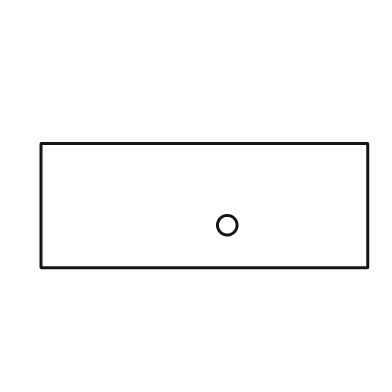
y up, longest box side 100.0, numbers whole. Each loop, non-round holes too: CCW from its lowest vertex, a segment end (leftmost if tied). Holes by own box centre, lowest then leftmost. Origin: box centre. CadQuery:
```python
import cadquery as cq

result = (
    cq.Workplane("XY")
    .moveTo(-50.0, -19.0)
    .lineTo(50.0, -19.0)
    .lineTo(50.0, 19.0)
    .lineTo(-50.0, 19.0)
    .close()
    .moveTo(7.0, -6.0)
    .circle(3.0)
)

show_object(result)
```